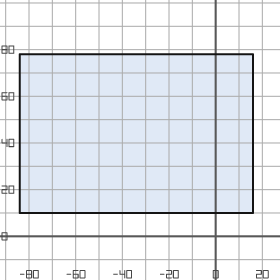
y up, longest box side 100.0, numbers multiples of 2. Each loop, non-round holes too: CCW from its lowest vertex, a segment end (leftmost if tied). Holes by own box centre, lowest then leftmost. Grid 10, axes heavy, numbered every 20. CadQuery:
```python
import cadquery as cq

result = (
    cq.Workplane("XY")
    .moveTo(-84.0, 10.0)
    .lineTo(16.0, 10.0)
    .lineTo(16.0, 78.0)
    .lineTo(-84.0, 78.0)
    .close()
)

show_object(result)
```